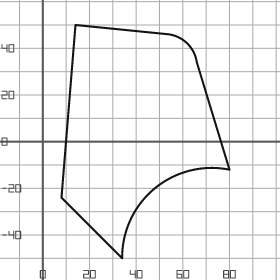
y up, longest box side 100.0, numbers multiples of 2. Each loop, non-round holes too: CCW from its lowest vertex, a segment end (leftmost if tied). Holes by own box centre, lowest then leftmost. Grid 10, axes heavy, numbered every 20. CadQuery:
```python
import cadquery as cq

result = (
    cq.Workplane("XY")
    .moveTo(34.0, -50.0)
    .threePointArc((48.0, -20.0), (80.0, -12.0))
    .lineTo(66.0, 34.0)
    .threePointArc((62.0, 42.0), (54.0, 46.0))
    .lineTo(14.0, 50.0)
    .lineTo(8.0, -24.0)
    .close()
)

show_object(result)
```